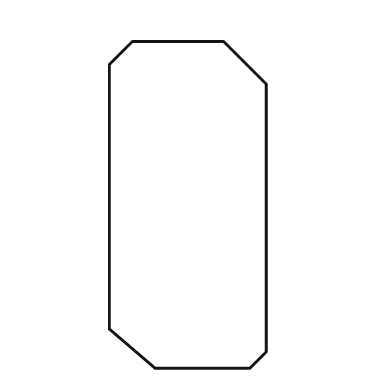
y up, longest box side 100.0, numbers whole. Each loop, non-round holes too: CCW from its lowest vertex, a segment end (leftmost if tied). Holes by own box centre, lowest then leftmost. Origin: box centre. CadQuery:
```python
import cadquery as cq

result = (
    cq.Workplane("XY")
    .moveTo(-10.0, -50.0)
    .lineTo(19.0, -50.0)
    .lineTo(24.0, -45.0)
    .lineTo(24.0, 37.0)
    .lineTo(11.0, 50.0)
    .lineTo(-17.0, 50.0)
    .lineTo(-24.0, 43.0)
    .lineTo(-24.0, -38.0)
    .close()
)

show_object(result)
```